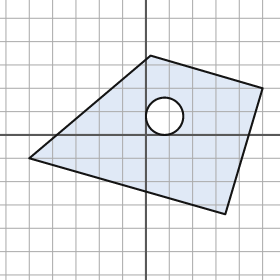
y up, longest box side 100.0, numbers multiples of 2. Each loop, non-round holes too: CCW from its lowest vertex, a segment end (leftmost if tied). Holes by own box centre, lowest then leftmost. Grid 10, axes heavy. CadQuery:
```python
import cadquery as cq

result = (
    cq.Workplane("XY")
    .moveTo(34.0, -34.0)
    .lineTo(50.0, 20.0)
    .lineTo(2.0, 34.0)
    .lineTo(-50.0, -10.0)
    .close()
    .moveTo(8.0, 8.0)
    .circle(8.0)
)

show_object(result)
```